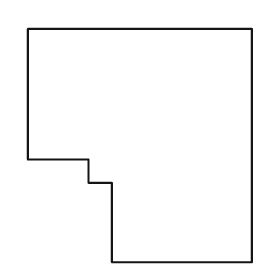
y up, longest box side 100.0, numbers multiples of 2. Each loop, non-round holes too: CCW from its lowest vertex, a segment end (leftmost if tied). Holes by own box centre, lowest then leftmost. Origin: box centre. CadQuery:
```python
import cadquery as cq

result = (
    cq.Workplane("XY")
    .moveTo(-12.0, -50.0)
    .lineTo(48.0, -50.0)
    .lineTo(48.0, 50.0)
    .lineTo(-48.0, 50.0)
    .lineTo(-48.0, -6.0)
    .lineTo(-22.0, -6.0)
    .lineTo(-22.0, -16.0)
    .lineTo(-12.0, -16.0)
    .close()
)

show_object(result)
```